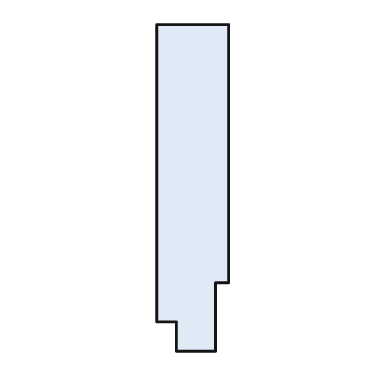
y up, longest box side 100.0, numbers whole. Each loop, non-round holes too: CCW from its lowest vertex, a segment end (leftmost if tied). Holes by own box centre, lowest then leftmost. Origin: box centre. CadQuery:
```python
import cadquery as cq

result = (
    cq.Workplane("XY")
    .moveTo(-5.0, -50.0)
    .lineTo(7.0, -50.0)
    .lineTo(7.0, -29.0)
    .lineTo(11.0, -29.0)
    .lineTo(11.0, 50.0)
    .lineTo(-11.0, 50.0)
    .lineTo(-11.0, -41.0)
    .lineTo(-5.0, -41.0)
    .close()
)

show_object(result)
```